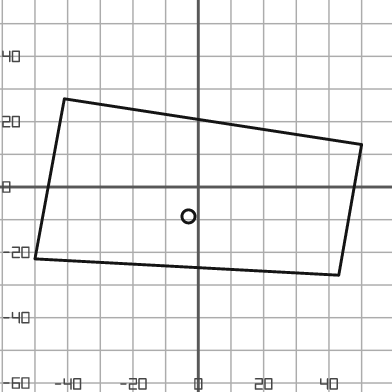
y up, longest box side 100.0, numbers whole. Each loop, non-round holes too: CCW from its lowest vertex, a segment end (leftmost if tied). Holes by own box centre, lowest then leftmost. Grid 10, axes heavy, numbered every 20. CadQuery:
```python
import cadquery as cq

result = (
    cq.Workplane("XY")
    .moveTo(43.0, -27.0)
    .lineTo(50.0, 13.0)
    .lineTo(-41.0, 27.0)
    .lineTo(-50.0, -22.0)
    .close()
    .moveTo(-3.0, -9.0)
    .circle(2.0)
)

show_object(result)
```